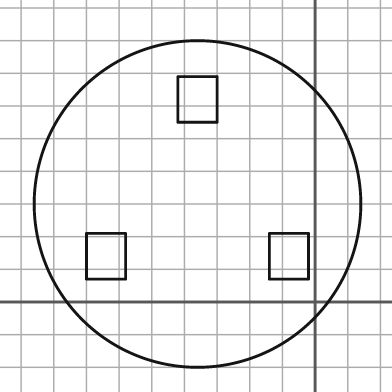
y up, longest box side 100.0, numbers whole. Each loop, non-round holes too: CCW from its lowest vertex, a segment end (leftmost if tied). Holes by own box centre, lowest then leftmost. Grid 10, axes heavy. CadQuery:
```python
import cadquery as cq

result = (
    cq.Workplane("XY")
    .moveTo(-36.0, 30.0)
    .circle(50.0)
    .moveTo(-70.0, 7.0)
    .lineTo(-58.0, 7.0)
    .lineTo(-58.0, 21.0)
    .lineTo(-70.0, 21.0)
    .close()
    .moveTo(-14.0, 7.0)
    .lineTo(-2.0, 7.0)
    .lineTo(-2.0, 21.0)
    .lineTo(-14.0, 21.0)
    .close()
    .moveTo(-42.0, 55.0)
    .lineTo(-30.0, 55.0)
    .lineTo(-30.0, 69.0)
    .lineTo(-42.0, 69.0)
    .close()
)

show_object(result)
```